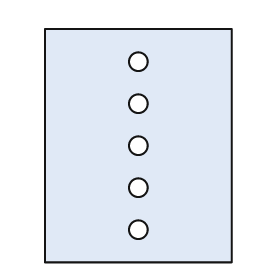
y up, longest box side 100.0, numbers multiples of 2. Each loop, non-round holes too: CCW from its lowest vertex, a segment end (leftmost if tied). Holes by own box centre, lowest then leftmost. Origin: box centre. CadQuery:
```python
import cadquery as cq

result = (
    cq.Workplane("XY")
    .moveTo(-40.0, -50.0)
    .lineTo(40.0, -50.0)
    .lineTo(40.0, 50.0)
    .lineTo(-40.0, 50.0)
    .close()
    .moveTo(0.0, -36.0)
    .circle(4.0)
    .moveTo(0.0, -18.0)
    .circle(4.0)
    .moveTo(0.0, 0.0)
    .circle(4.0)
    .moveTo(0.0, 18.0)
    .circle(4.0)
    .moveTo(0.0, 36.0)
    .circle(4.0)
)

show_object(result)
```